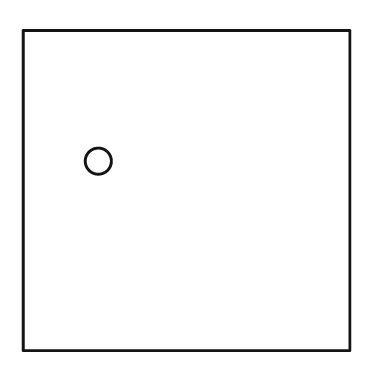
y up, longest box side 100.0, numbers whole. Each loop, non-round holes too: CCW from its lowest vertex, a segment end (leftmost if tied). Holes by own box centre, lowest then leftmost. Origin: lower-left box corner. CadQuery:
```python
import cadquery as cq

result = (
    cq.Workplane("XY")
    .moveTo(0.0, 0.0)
    .lineTo(100.0, 0.0)
    .lineTo(100.0, 98.0)
    .lineTo(0.0, 98.0)
    .close()
    .moveTo(23.0, 58.0)
    .circle(4.0)
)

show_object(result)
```